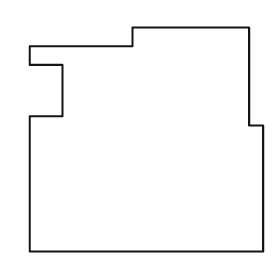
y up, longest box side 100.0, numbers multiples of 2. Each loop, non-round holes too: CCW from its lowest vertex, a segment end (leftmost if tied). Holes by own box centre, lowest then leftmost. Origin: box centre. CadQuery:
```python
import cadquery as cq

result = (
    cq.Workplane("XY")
    .moveTo(-50.0, -48.0)
    .lineTo(50.0, -48.0)
    .lineTo(50.0, 6.0)
    .lineTo(44.0, 6.0)
    .lineTo(44.0, 48.0)
    .lineTo(-6.0, 48.0)
    .lineTo(-6.0, 40.0)
    .lineTo(-50.0, 40.0)
    .lineTo(-50.0, 32.0)
    .lineTo(-36.0, 32.0)
    .lineTo(-36.0, 10.0)
    .lineTo(-50.0, 10.0)
    .close()
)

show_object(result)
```